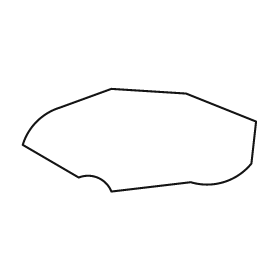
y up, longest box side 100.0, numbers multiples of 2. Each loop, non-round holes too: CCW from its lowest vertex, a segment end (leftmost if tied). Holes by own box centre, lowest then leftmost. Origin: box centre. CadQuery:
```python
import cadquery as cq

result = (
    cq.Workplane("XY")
    .moveTo(-12.0, -22.0)
    .lineTo(22.0, -18.0)
    .threePointArc((36.0, -18.0), (48.0, -10.0))
    .lineTo(50.0, 8.0)
    .lineTo(20.0, 20.0)
    .lineTo(-12.0, 22.0)
    .lineTo(-34.0, 14.0)
    .threePointArc((-44.0, 8.0), (-50.0, -2.0))
    .lineTo(-26.0, -16.0)
    .threePointArc((-18.0, -16.0), (-12.0, -22.0))
    .close()
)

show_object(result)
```